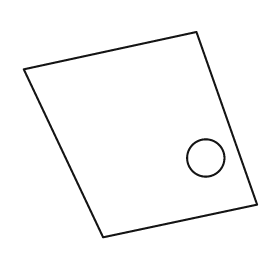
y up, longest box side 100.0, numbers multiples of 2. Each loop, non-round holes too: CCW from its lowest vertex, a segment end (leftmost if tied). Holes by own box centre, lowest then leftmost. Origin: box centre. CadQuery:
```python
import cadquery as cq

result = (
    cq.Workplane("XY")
    .moveTo(-16.0, -44.0)
    .lineTo(50.0, -30.0)
    .lineTo(24.0, 44.0)
    .lineTo(-50.0, 28.0)
    .close()
    .moveTo(28.0, -10.0)
    .circle(8.0)
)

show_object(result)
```